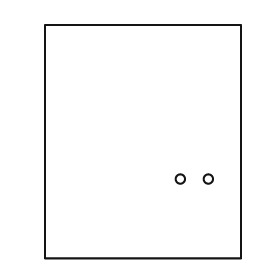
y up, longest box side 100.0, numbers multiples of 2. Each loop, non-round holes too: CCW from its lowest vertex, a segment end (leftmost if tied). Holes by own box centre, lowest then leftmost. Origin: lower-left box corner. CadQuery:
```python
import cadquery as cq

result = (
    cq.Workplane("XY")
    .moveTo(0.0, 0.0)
    .lineTo(84.0, 0.0)
    .lineTo(84.0, 100.0)
    .lineTo(0.0, 100.0)
    .close()
    .moveTo(58.0, 34.0)
    .circle(2.0)
    .moveTo(70.0, 34.0)
    .circle(2.0)
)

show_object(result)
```